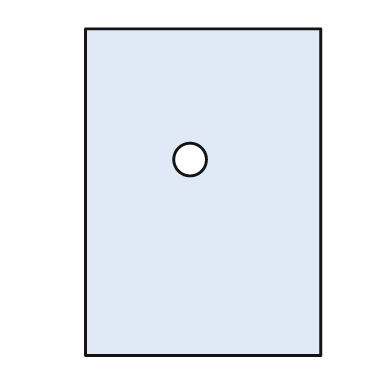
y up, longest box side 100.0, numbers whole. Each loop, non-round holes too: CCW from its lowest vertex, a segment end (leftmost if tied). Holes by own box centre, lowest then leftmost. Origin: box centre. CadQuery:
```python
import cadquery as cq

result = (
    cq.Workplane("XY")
    .moveTo(-36.0, -50.0)
    .lineTo(36.0, -50.0)
    .lineTo(36.0, 50.0)
    .lineTo(-36.0, 50.0)
    .close()
    .moveTo(-4.0, 10.0)
    .circle(5.0)
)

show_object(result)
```